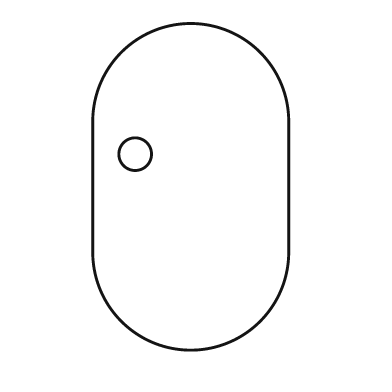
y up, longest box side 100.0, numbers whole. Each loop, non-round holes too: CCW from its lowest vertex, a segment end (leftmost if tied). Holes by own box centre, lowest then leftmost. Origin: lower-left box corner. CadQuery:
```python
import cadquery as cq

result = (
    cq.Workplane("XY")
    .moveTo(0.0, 30.0)
    .threePointArc((30.0, 0.0), (60.0, 30.0))
    .lineTo(60.0, 70.0)
    .threePointArc((30.0, 100.0), (0.0, 70.0))
    .close()
    .moveTo(13.0, 60.0)
    .circle(5.0)
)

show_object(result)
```